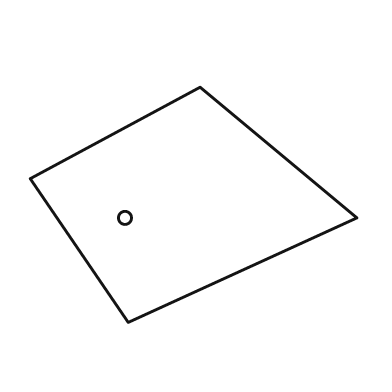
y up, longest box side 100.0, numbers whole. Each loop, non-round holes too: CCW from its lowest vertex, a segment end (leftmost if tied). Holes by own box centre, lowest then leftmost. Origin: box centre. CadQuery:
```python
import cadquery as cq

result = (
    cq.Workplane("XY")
    .moveTo(-20.0, -36.0)
    .lineTo(50.0, -4.0)
    .lineTo(2.0, 36.0)
    .lineTo(-50.0, 8.0)
    .close()
    .moveTo(-21.0, -4.0)
    .circle(2.0)
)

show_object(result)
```